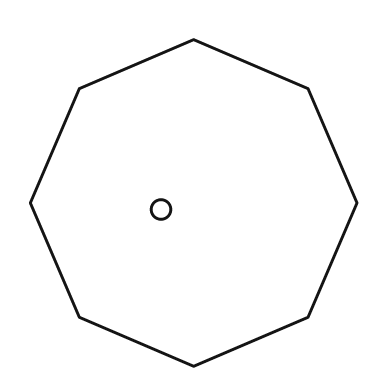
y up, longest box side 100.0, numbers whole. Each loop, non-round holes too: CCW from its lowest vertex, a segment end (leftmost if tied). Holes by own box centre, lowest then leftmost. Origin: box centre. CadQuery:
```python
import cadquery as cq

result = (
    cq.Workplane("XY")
    .moveTo(0.0, -50.0)
    .lineTo(35.0, -35.0)
    .lineTo(50.0, 0.0)
    .lineTo(35.0, 35.0)
    .lineTo(0.0, 50.0)
    .lineTo(-35.0, 35.0)
    .lineTo(-50.0, 0.0)
    .lineTo(-35.0, -35.0)
    .close()
    .moveTo(-10.0, -2.0)
    .circle(3.0)
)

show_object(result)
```